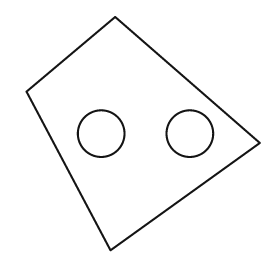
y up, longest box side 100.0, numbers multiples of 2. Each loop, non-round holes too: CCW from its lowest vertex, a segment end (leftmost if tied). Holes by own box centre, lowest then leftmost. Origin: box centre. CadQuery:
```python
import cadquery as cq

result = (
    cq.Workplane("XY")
    .moveTo(-14.0, -50.0)
    .lineTo(50.0, -4.0)
    .lineTo(-12.0, 50.0)
    .lineTo(-50.0, 18.0)
    .close()
    .moveTo(-18.0, 0.0)
    .circle(10.0)
    .moveTo(20.0, 0.0)
    .circle(10.0)
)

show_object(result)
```